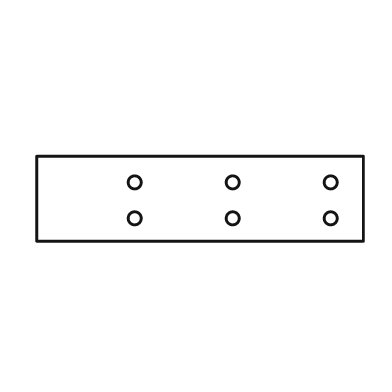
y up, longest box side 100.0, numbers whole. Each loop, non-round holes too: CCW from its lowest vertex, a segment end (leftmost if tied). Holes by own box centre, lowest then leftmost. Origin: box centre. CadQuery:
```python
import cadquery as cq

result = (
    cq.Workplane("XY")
    .moveTo(-50.0, -13.0)
    .lineTo(50.0, -13.0)
    .lineTo(50.0, 13.0)
    .lineTo(-50.0, 13.0)
    .close()
    .moveTo(-20.0, -6.0)
    .circle(2.0)
    .moveTo(10.0, -6.0)
    .circle(2.0)
    .moveTo(40.0, -6.0)
    .circle(2.0)
    .moveTo(-20.0, 5.0)
    .circle(2.0)
    .moveTo(10.0, 5.0)
    .circle(2.0)
    .moveTo(40.0, 5.0)
    .circle(2.0)
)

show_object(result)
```